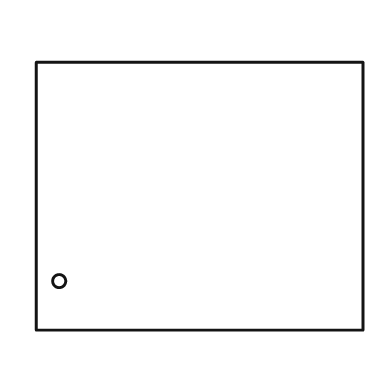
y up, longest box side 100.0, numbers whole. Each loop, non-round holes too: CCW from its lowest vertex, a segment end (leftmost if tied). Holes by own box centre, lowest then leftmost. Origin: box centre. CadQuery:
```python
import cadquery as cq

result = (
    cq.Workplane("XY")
    .moveTo(-50.0, -41.0)
    .lineTo(50.0, -41.0)
    .lineTo(50.0, 41.0)
    .lineTo(-50.0, 41.0)
    .close()
    .moveTo(-43.0, -26.0)
    .circle(2.0)
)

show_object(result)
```